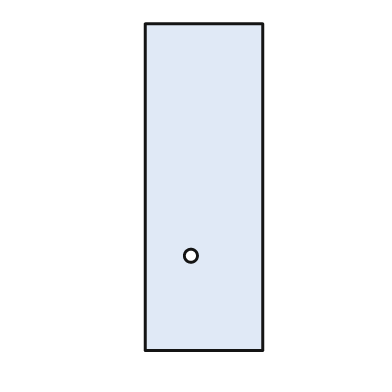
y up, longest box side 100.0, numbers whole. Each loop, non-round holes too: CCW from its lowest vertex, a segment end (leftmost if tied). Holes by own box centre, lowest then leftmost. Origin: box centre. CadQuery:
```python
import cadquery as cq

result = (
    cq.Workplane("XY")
    .moveTo(-18.0, -50.0)
    .lineTo(18.0, -50.0)
    .lineTo(18.0, 50.0)
    .lineTo(-18.0, 50.0)
    .close()
    .moveTo(-4.0, -21.0)
    .circle(2.0)
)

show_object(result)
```